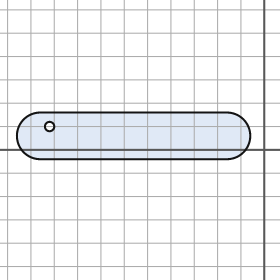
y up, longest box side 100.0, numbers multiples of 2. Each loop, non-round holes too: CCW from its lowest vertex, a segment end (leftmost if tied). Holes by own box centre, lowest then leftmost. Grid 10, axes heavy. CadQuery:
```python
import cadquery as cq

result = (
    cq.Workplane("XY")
    .moveTo(-96.0, -4.0)
    .lineTo(-16.0, -4.0)
    .threePointArc((-6.0, 6.0), (-16.0, 16.0))
    .lineTo(-96.0, 16.0)
    .threePointArc((-106.0, 6.0), (-96.0, -4.0))
    .close()
    .moveTo(-92.0, 10.0)
    .circle(2.0)
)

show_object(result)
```